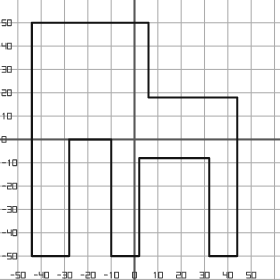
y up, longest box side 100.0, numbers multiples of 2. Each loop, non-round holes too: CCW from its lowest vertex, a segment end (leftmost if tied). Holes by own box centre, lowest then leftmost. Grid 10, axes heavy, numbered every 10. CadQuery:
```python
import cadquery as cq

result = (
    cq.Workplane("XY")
    .moveTo(-44.0, -50.0)
    .lineTo(-28.0, -50.0)
    .lineTo(-28.0, 0.0)
    .lineTo(-10.0, 0.0)
    .lineTo(-10.0, -50.0)
    .lineTo(2.0, -50.0)
    .lineTo(2.0, -8.0)
    .lineTo(32.0, -8.0)
    .lineTo(32.0, -50.0)
    .lineTo(44.0, -50.0)
    .lineTo(44.0, 18.0)
    .lineTo(6.0, 18.0)
    .lineTo(6.0, 50.0)
    .lineTo(-44.0, 50.0)
    .close()
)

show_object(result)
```